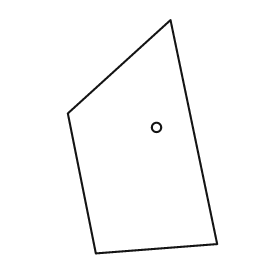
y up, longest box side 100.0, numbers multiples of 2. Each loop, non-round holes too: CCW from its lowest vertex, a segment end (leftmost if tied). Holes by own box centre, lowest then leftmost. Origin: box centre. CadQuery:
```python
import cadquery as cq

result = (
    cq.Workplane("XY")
    .moveTo(-20.0, -50.0)
    .lineTo(32.0, -46.0)
    .lineTo(12.0, 50.0)
    .lineTo(-32.0, 10.0)
    .close()
    .moveTo(6.0, 4.0)
    .circle(2.0)
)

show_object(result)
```